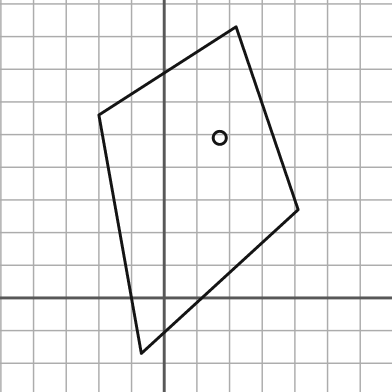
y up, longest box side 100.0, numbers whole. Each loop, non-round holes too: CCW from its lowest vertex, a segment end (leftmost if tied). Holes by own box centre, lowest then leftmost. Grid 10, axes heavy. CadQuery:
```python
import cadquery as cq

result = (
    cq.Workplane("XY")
    .moveTo(-7.0, -17.0)
    .lineTo(41.0, 27.0)
    .lineTo(22.0, 83.0)
    .lineTo(-20.0, 56.0)
    .close()
    .moveTo(17.0, 49.0)
    .circle(2.0)
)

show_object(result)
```